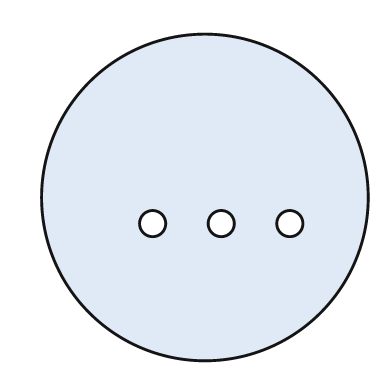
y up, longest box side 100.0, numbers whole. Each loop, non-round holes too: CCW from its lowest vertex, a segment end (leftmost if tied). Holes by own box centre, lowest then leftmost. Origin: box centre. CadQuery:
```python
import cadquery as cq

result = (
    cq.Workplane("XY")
    .moveTo(0.0, 0.0)
    .circle(50.0)
    .moveTo(-16.0, -8.0)
    .circle(4.0)
    .moveTo(5.0, -8.0)
    .circle(4.0)
    .moveTo(26.0, -8.0)
    .circle(4.0)
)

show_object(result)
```